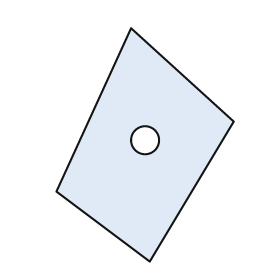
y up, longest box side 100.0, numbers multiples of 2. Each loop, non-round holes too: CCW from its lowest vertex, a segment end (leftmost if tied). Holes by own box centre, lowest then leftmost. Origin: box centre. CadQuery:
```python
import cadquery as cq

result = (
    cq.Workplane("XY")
    .moveTo(2.0, -50.0)
    .lineTo(38.0, 10.0)
    .lineTo(-6.0, 50.0)
    .lineTo(-38.0, -20.0)
    .close()
    .moveTo(0.0, 2.0)
    .circle(6.0)
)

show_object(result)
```